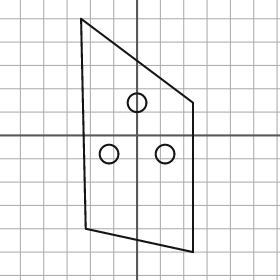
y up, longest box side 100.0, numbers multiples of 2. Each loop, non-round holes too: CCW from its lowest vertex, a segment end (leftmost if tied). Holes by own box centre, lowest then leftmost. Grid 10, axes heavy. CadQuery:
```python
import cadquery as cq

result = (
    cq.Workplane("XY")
    .moveTo(24.0, -50.0)
    .lineTo(24.0, 14.0)
    .lineTo(-24.0, 50.0)
    .lineTo(-22.0, -40.0)
    .close()
    .moveTo(-12.0, -8.0)
    .circle(4.0)
    .moveTo(12.0, -8.0)
    .circle(4.0)
    .moveTo(0.0, 14.0)
    .circle(4.0)
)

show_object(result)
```